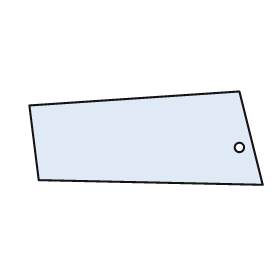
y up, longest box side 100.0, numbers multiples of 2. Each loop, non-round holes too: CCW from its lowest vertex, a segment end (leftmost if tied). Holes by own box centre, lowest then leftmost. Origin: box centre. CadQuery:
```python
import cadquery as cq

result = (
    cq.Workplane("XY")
    .moveTo(50.0, -20.0)
    .lineTo(40.0, 20.0)
    .lineTo(-50.0, 14.0)
    .lineTo(-46.0, -18.0)
    .close()
    .moveTo(40.0, -4.0)
    .circle(2.0)
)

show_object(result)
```